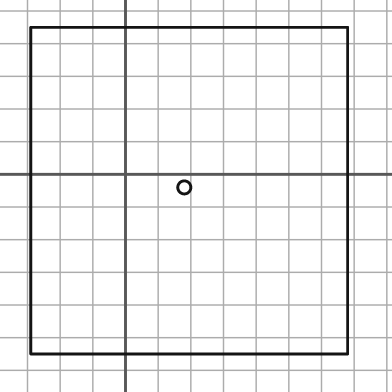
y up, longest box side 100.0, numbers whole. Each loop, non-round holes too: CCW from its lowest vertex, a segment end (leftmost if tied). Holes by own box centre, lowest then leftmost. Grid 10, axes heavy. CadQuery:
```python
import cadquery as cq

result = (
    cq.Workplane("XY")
    .moveTo(-29.0, -55.0)
    .lineTo(68.0, -55.0)
    .lineTo(68.0, 45.0)
    .lineTo(-29.0, 45.0)
    .close()
    .moveTo(18.0, -4.0)
    .circle(2.0)
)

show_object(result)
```